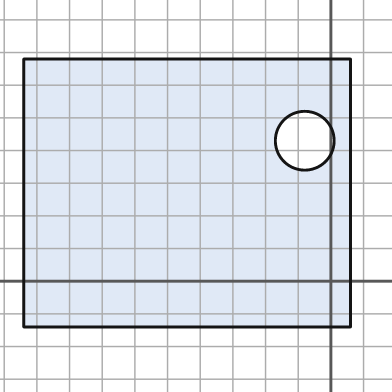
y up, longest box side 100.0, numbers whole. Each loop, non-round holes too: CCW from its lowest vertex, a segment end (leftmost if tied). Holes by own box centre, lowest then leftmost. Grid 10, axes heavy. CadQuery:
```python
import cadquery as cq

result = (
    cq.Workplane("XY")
    .moveTo(-94.0, -14.0)
    .lineTo(6.0, -14.0)
    .lineTo(6.0, 68.0)
    .lineTo(-94.0, 68.0)
    .close()
    .moveTo(-8.0, 43.0)
    .circle(9.0)
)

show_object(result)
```